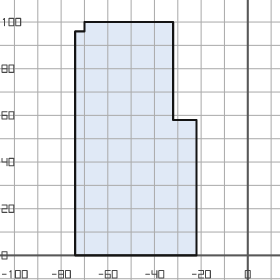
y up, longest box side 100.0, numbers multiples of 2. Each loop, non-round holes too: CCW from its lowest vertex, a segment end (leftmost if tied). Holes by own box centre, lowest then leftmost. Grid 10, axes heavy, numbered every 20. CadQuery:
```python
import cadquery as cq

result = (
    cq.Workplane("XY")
    .moveTo(-74.0, 0.0)
    .lineTo(-22.0, 0.0)
    .lineTo(-22.0, 58.0)
    .lineTo(-32.0, 58.0)
    .lineTo(-32.0, 100.0)
    .lineTo(-70.0, 100.0)
    .lineTo(-70.0, 96.0)
    .lineTo(-74.0, 96.0)
    .close()
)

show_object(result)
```